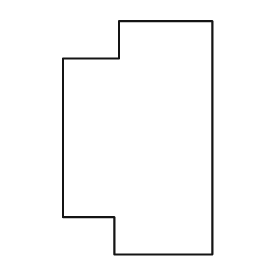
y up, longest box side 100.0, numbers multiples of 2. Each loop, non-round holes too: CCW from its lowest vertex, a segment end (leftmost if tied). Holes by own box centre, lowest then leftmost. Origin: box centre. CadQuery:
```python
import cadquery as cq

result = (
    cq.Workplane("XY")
    .moveTo(-10.0, -50.0)
    .lineTo(32.0, -50.0)
    .lineTo(32.0, 50.0)
    .lineTo(-8.0, 50.0)
    .lineTo(-8.0, 34.0)
    .lineTo(-32.0, 34.0)
    .lineTo(-32.0, -34.0)
    .lineTo(-10.0, -34.0)
    .close()
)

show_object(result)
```